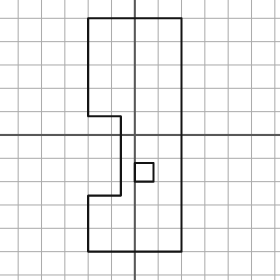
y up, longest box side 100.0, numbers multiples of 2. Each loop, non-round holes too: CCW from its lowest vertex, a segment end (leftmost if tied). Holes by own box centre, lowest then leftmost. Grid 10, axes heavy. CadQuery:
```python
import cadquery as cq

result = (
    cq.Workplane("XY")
    .moveTo(-20.0, -50.0)
    .lineTo(20.0, -50.0)
    .lineTo(20.0, 50.0)
    .lineTo(-20.0, 50.0)
    .lineTo(-20.0, 8.0)
    .lineTo(-6.0, 8.0)
    .lineTo(-6.0, -26.0)
    .lineTo(-20.0, -26.0)
    .close()
    .moveTo(0.0, -20.0)
    .lineTo(8.0, -20.0)
    .lineTo(8.0, -12.0)
    .lineTo(0.0, -12.0)
    .close()
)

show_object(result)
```